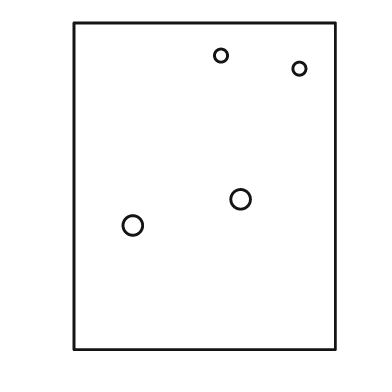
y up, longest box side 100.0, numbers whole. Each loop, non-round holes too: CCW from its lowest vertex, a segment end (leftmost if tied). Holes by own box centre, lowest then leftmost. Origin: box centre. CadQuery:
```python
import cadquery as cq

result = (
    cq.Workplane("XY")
    .moveTo(-40.0, -50.0)
    .lineTo(40.0, -50.0)
    .lineTo(40.0, 50.0)
    .lineTo(-40.0, 50.0)
    .close()
    .moveTo(-22.0, -12.0)
    .circle(3.0)
    .moveTo(11.0, -4.0)
    .circle(3.0)
    .moveTo(29.0, 36.0)
    .circle(2.0)
    .moveTo(5.0, 40.0)
    .circle(2.0)
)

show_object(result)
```